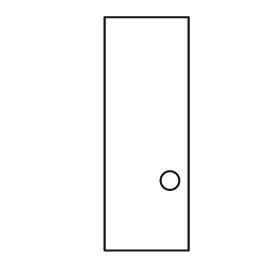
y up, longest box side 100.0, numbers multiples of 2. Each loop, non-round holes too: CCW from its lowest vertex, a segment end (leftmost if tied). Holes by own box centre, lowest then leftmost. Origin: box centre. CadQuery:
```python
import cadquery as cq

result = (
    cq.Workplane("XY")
    .moveTo(-18.0, -50.0)
    .lineTo(18.0, -50.0)
    .lineTo(18.0, 50.0)
    .lineTo(-18.0, 50.0)
    .close()
    .moveTo(10.0, -20.0)
    .circle(4.0)
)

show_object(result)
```